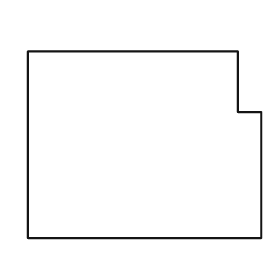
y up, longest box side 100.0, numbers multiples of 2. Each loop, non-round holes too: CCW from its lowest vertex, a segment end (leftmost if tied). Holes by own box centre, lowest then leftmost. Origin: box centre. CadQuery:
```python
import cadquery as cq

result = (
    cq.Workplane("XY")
    .moveTo(-50.0, -40.0)
    .lineTo(50.0, -40.0)
    .lineTo(50.0, 14.0)
    .lineTo(40.0, 14.0)
    .lineTo(40.0, 40.0)
    .lineTo(-50.0, 40.0)
    .close()
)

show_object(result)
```